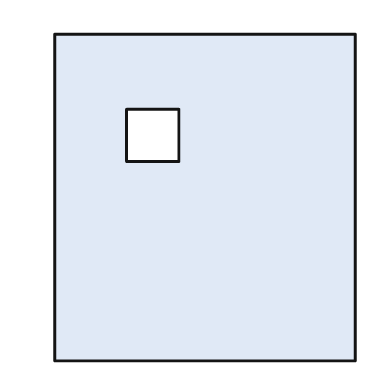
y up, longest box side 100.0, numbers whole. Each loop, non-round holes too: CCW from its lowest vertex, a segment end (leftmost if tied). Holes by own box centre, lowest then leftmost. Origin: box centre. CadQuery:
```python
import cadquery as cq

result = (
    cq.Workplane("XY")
    .moveTo(-46.0, -50.0)
    .lineTo(46.0, -50.0)
    .lineTo(46.0, 50.0)
    .lineTo(-46.0, 50.0)
    .close()
    .moveTo(-24.0, 11.0)
    .lineTo(-8.0, 11.0)
    .lineTo(-8.0, 27.0)
    .lineTo(-24.0, 27.0)
    .close()
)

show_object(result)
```